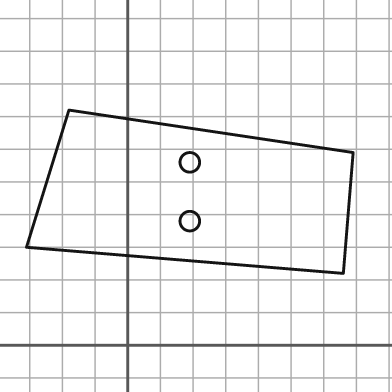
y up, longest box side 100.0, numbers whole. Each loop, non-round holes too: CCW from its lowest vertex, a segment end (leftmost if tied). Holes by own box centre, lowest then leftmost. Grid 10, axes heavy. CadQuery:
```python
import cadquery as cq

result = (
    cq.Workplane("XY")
    .moveTo(66.0, 22.0)
    .lineTo(69.0, 59.0)
    .lineTo(-18.0, 72.0)
    .lineTo(-31.0, 30.0)
    .close()
    .moveTo(19.0, 38.0)
    .circle(3.0)
    .moveTo(19.0, 56.0)
    .circle(3.0)
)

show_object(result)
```